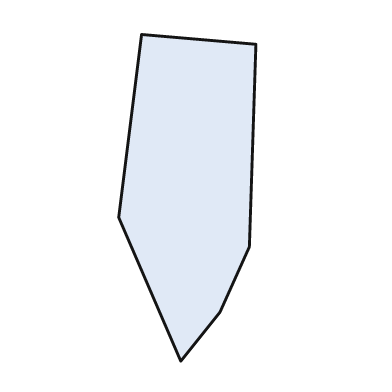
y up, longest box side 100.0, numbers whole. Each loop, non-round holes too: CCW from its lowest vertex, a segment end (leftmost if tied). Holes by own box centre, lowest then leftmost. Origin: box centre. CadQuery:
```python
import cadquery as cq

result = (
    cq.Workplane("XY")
    .moveTo(-2.0, -50.0)
    .lineTo(10.0, -35.0)
    .lineTo(19.0, -15.0)
    .lineTo(21.0, 47.0)
    .lineTo(-14.0, 50.0)
    .lineTo(-21.0, -6.0)
    .close()
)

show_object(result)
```